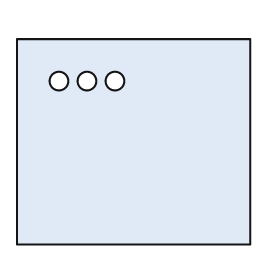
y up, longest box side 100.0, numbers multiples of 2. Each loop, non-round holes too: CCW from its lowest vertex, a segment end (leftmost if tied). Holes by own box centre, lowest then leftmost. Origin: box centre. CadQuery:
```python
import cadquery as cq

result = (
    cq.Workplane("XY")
    .moveTo(-50.0, -44.0)
    .lineTo(50.0, -44.0)
    .lineTo(50.0, 44.0)
    .lineTo(-50.0, 44.0)
    .close()
    .moveTo(-32.0, 26.0)
    .circle(4.0)
    .moveTo(-20.0, 26.0)
    .circle(4.0)
    .moveTo(-8.0, 26.0)
    .circle(4.0)
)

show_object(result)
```